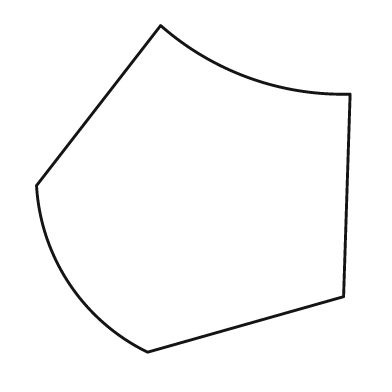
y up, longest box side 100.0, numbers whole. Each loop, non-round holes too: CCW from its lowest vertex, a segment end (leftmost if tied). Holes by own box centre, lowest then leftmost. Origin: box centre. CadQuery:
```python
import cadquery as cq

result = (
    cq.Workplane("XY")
    .moveTo(-14.0, -50.0)
    .lineTo(46.0, -33.0)
    .lineTo(48.0, 29.0)
    .threePointArc((17.0, 34.0), (-10.0, 50.0))
    .lineTo(-48.0, 1.0)
    .threePointArc((-38.0, -29.0), (-14.0, -50.0))
    .close()
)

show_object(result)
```